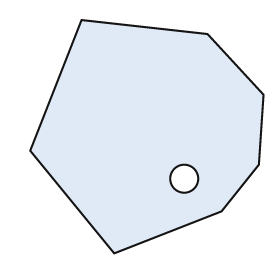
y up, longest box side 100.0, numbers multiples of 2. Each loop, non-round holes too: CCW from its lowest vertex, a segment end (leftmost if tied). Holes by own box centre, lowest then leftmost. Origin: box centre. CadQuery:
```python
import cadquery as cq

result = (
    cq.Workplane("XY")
    .moveTo(-14.0, -50.0)
    .lineTo(32.0, -32.0)
    .lineTo(48.0, -12.0)
    .lineTo(50.0, 18.0)
    .lineTo(26.0, 44.0)
    .lineTo(-28.0, 50.0)
    .lineTo(-50.0, -6.0)
    .close()
    .moveTo(16.0, -18.0)
    .circle(6.0)
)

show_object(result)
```